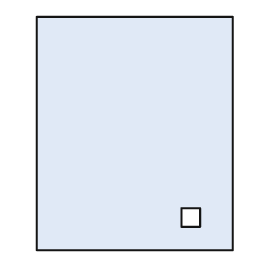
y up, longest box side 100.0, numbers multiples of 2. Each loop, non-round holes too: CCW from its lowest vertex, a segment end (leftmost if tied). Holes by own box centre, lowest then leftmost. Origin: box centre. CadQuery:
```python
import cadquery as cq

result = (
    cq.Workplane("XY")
    .moveTo(-42.0, -50.0)
    .lineTo(42.0, -50.0)
    .lineTo(42.0, 50.0)
    .lineTo(-42.0, 50.0)
    .close()
    .moveTo(20.0, -40.0)
    .lineTo(28.0, -40.0)
    .lineTo(28.0, -32.0)
    .lineTo(20.0, -32.0)
    .close()
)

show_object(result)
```